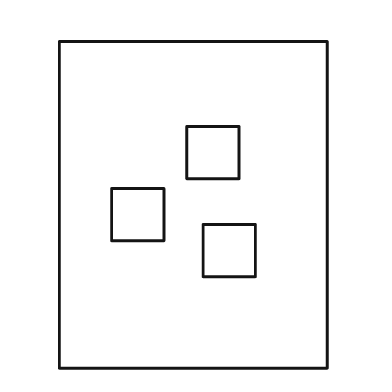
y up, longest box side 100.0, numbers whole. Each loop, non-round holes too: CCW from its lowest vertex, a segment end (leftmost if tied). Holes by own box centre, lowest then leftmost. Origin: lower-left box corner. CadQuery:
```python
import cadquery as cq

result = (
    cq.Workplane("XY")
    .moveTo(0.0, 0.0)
    .lineTo(82.0, 0.0)
    .lineTo(82.0, 100.0)
    .lineTo(0.0, 100.0)
    .close()
    .moveTo(44.0, 28.0)
    .lineTo(60.0, 28.0)
    .lineTo(60.0, 44.0)
    .lineTo(44.0, 44.0)
    .close()
    .moveTo(16.0, 39.0)
    .lineTo(32.0, 39.0)
    .lineTo(32.0, 55.0)
    .lineTo(16.0, 55.0)
    .close()
    .moveTo(39.0, 58.0)
    .lineTo(55.0, 58.0)
    .lineTo(55.0, 74.0)
    .lineTo(39.0, 74.0)
    .close()
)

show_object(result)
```